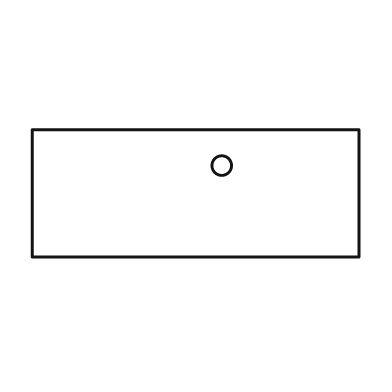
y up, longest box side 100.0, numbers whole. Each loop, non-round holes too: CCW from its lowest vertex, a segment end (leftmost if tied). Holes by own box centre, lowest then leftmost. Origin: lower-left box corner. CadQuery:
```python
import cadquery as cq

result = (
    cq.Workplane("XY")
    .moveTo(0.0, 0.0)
    .lineTo(100.0, 0.0)
    .lineTo(100.0, 39.0)
    .lineTo(0.0, 39.0)
    .close()
    .moveTo(58.0, 28.0)
    .circle(3.0)
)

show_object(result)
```